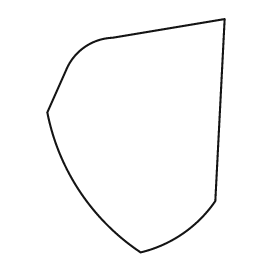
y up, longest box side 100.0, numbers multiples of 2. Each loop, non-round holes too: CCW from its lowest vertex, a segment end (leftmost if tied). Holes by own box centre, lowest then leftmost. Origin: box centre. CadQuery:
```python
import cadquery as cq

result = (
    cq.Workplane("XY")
    .moveTo(2.0, -50.0)
    .threePointArc((20.0, -42.0), (34.0, -28.0))
    .lineTo(38.0, 50.0)
    .lineTo(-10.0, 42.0)
    .threePointArc((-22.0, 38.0), (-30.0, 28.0))
    .lineTo(-38.0, 10.0)
    .threePointArc((-24.0, -24.0), (2.0, -50.0))
    .close()
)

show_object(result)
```